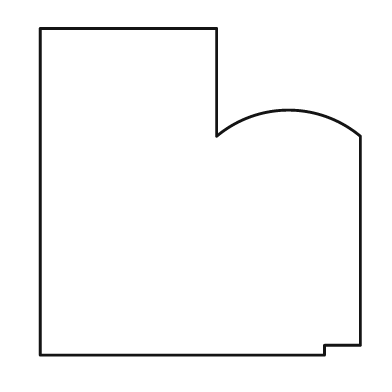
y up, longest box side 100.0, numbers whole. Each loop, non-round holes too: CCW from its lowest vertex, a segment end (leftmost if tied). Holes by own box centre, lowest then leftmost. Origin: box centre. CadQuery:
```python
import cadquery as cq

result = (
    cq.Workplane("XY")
    .moveTo(-49.0, -50.0)
    .lineTo(38.0, -50.0)
    .lineTo(38.0, -47.0)
    .lineTo(49.0, -47.0)
    .lineTo(49.0, 17.0)
    .threePointArc((27.0, 25.0), (5.0, 17.0))
    .lineTo(5.0, 50.0)
    .lineTo(-49.0, 50.0)
    .close()
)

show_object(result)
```